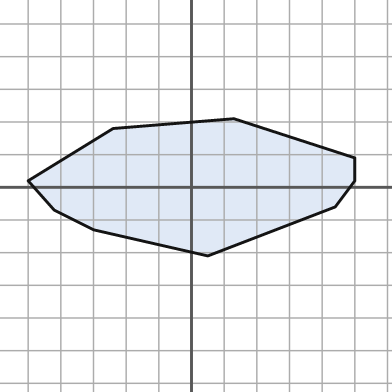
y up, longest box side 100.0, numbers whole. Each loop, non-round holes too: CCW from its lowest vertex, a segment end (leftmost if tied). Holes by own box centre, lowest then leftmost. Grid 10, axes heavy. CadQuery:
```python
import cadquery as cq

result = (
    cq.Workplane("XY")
    .moveTo(5.0, -21.0)
    .lineTo(44.0, -6.0)
    .lineTo(50.0, 2.0)
    .lineTo(50.0, 9.0)
    .lineTo(13.0, 21.0)
    .lineTo(-24.0, 18.0)
    .lineTo(-50.0, 2.0)
    .lineTo(-42.0, -7.0)
    .lineTo(-30.0, -13.0)
    .close()
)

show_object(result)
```